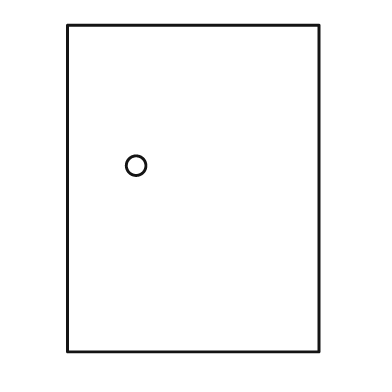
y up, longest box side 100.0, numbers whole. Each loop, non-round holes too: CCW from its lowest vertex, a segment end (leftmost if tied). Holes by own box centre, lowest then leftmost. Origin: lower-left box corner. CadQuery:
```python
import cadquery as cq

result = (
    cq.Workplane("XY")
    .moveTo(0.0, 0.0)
    .lineTo(77.0, 0.0)
    .lineTo(77.0, 100.0)
    .lineTo(0.0, 100.0)
    .close()
    .moveTo(21.0, 57.0)
    .circle(3.0)
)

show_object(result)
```